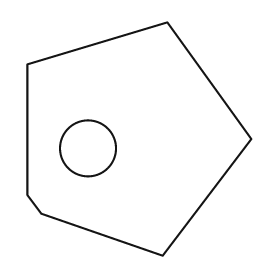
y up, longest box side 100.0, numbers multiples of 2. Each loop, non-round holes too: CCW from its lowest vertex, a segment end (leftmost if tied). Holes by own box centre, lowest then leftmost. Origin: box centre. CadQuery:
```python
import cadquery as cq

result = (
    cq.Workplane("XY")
    .moveTo(10.0, -50.0)
    .lineTo(48.0, 0.0)
    .lineTo(12.0, 50.0)
    .lineTo(-48.0, 32.0)
    .lineTo(-48.0, -24.0)
    .lineTo(-42.0, -32.0)
    .close()
    .moveTo(-22.0, -4.0)
    .circle(12.0)
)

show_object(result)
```